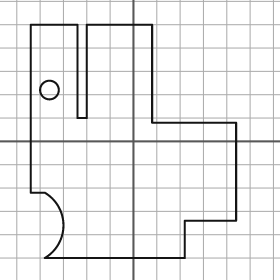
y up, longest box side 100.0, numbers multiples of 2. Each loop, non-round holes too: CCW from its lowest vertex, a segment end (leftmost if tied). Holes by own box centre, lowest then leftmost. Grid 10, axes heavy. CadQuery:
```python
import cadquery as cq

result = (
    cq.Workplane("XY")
    .moveTo(-38.0, -50.0)
    .lineTo(22.0, -50.0)
    .lineTo(22.0, -34.0)
    .lineTo(44.0, -34.0)
    .lineTo(44.0, 8.0)
    .lineTo(8.0, 8.0)
    .lineTo(8.0, 50.0)
    .lineTo(-20.0, 50.0)
    .lineTo(-20.0, 10.0)
    .lineTo(-24.0, 10.0)
    .lineTo(-24.0, 50.0)
    .lineTo(-44.0, 50.0)
    .lineTo(-44.0, -22.0)
    .lineTo(-38.0, -22.0)
    .threePointArc((-30.0, -36.0), (-38.0, -50.0))
    .close()
    .moveTo(-36.0, 22.0)
    .circle(4.0)
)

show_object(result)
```